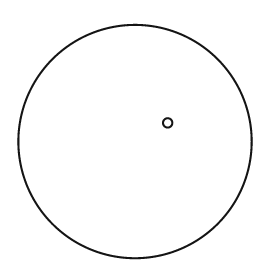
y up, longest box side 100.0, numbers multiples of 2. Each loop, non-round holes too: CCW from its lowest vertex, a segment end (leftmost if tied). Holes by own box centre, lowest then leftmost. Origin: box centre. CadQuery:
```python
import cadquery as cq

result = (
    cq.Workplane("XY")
    .moveTo(0.0, 0.0)
    .circle(50.0)
    .moveTo(14.0, 8.0)
    .circle(2.0)
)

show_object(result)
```